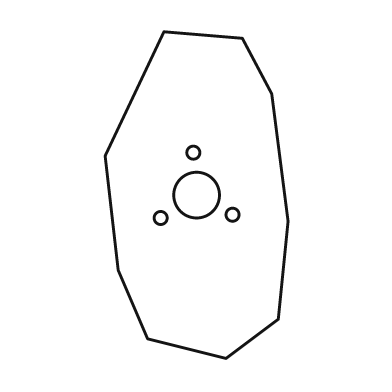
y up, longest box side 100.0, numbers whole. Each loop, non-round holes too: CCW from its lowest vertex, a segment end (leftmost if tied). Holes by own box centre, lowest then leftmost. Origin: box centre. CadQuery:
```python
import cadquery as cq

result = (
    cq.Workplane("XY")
    .moveTo(9.0, -50.0)
    .lineTo(25.0, -38.0)
    .lineTo(28.0, -8.0)
    .lineTo(23.0, 31.0)
    .lineTo(14.0, 48.0)
    .lineTo(-10.0, 50.0)
    .lineTo(-28.0, 12.0)
    .lineTo(-24.0, -23.0)
    .lineTo(-15.0, -44.0)
    .close()
    .moveTo(-11.0, -7.0)
    .circle(2.0)
    .moveTo(11.0, -6.0)
    .circle(2.0)
    .moveTo(0.0, 0.0)
    .circle(7.0)
    .moveTo(-1.0, 13.0)
    .circle(2.0)
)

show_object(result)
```